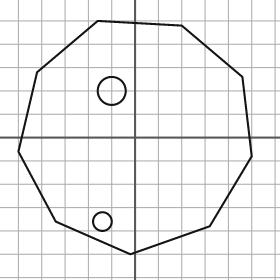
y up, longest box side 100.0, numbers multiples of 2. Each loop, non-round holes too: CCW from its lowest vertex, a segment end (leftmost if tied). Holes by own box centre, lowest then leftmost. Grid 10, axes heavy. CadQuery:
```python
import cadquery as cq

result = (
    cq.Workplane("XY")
    .moveTo(-2.0, -50.0)
    .lineTo(32.0, -38.0)
    .lineTo(50.0, -8.0)
    .lineTo(46.0, 26.0)
    .lineTo(20.0, 48.0)
    .lineTo(-16.0, 50.0)
    .lineTo(-42.0, 28.0)
    .lineTo(-50.0, -6.0)
    .lineTo(-34.0, -36.0)
    .close()
    .moveTo(-14.0, -36.0)
    .circle(4.0)
    .moveTo(-10.0, 20.0)
    .circle(6.0)
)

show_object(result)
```